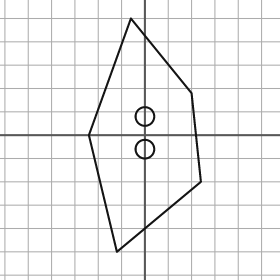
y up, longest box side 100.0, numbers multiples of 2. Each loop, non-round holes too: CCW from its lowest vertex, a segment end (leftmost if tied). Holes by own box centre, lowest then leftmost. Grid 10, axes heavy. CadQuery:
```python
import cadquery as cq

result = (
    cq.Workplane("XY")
    .moveTo(-12.0, -50.0)
    .lineTo(24.0, -20.0)
    .lineTo(20.0, 18.0)
    .lineTo(-6.0, 50.0)
    .lineTo(-24.0, 0.0)
    .close()
    .moveTo(0.0, -6.0)
    .circle(4.0)
    .moveTo(0.0, 8.0)
    .circle(4.0)
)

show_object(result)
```